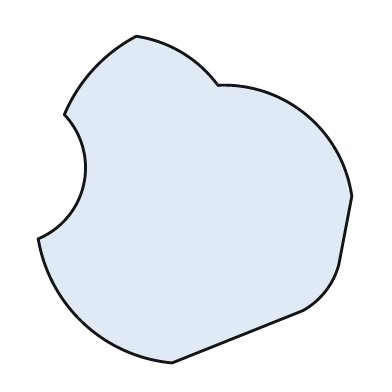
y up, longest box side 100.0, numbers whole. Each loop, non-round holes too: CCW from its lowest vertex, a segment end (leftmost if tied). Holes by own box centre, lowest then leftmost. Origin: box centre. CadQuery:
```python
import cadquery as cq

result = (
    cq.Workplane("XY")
    .moveTo(-7.0, -50.0)
    .lineTo(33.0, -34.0)
    .threePointArc((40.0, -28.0), (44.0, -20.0))
    .lineTo(48.0, 1.0)
    .threePointArc((34.0, 26.0), (7.0, 35.0))
    .threePointArc((-4.0, 45.0), (-18.0, 50.0))
    .threePointArc((-31.0, 40.0), (-40.0, 26.0))
    .threePointArc((-34.0, 5.0), (-48.0, -12.0))
    .threePointArc((-34.0, -38.0), (-7.0, -50.0))
    .close()
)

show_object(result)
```